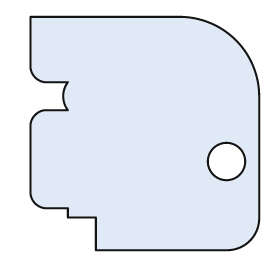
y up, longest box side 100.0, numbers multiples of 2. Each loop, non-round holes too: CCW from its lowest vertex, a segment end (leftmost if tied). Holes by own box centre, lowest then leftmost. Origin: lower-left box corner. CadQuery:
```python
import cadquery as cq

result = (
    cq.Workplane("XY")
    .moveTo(28.0, 0.0)
    .lineTo(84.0, 0.0)
    .threePointArc((94.0, 4.0), (98.0, 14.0))
    .lineTo(98.0, 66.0)
    .threePointArc((88.0, 90.0), (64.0, 100.0))
    .lineTo(0.0, 100.0)
    .lineTo(0.0, 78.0)
    .threePointArc((2.0, 74.0), (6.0, 72.0))
    .lineTo(16.0, 72.0)
    .threePointArc((14.0, 66.0), (16.0, 60.0))
    .lineTo(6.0, 60.0)
    .threePointArc((2.0, 58.0), (0.0, 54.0))
    .lineTo(0.0, 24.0)
    .threePointArc((2.0, 20.0), (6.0, 18.0))
    .lineTo(16.0, 18.0)
    .lineTo(16.0, 14.0)
    .lineTo(28.0, 14.0)
    .close()
    .moveTo(84.0, 38.0)
    .circle(8.0)
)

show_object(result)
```